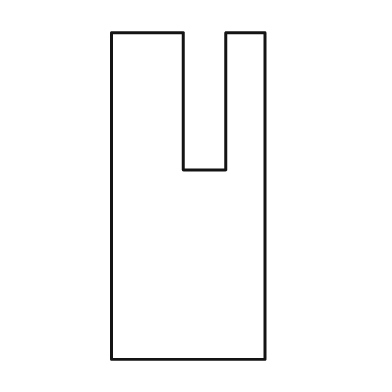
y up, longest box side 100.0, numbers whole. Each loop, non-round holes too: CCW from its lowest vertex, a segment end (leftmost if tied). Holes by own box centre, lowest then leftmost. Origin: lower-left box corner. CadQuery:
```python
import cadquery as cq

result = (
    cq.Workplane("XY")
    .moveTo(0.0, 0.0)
    .lineTo(47.0, 0.0)
    .lineTo(47.0, 100.0)
    .lineTo(35.0, 100.0)
    .lineTo(35.0, 58.0)
    .lineTo(22.0, 58.0)
    .lineTo(22.0, 100.0)
    .lineTo(0.0, 100.0)
    .close()
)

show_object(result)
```